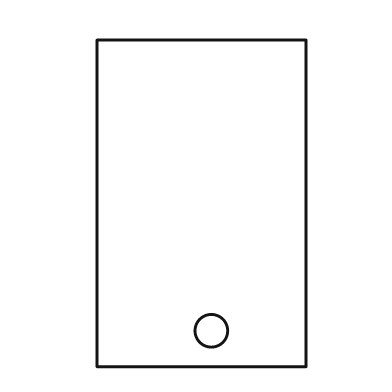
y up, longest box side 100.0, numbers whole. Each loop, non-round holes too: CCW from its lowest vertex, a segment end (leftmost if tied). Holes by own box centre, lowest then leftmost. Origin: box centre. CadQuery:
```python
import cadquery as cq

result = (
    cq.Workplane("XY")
    .moveTo(-32.0, -50.0)
    .lineTo(32.0, -50.0)
    .lineTo(32.0, 50.0)
    .lineTo(-32.0, 50.0)
    .close()
    .moveTo(3.0, -39.0)
    .circle(5.0)
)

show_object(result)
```